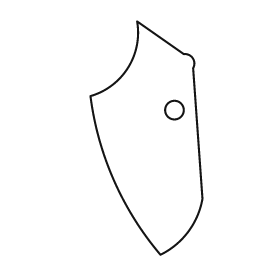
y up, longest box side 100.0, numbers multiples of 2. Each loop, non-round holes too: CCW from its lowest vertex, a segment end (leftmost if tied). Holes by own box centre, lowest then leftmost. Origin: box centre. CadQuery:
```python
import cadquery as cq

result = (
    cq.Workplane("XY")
    .moveTo(6.0, -50.0)
    .threePointArc((18.0, -40.0), (24.0, -26.0))
    .lineTo(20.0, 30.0)
    .threePointArc((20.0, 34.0), (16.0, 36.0))
    .lineTo(-4.0, 50.0)
    .threePointArc((-8.0, 30.0), (-24.0, 18.0))
    .threePointArc((-14.0, -18.0), (6.0, -50.0))
    .close()
    .moveTo(12.0, 12.0)
    .circle(4.0)
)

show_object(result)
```